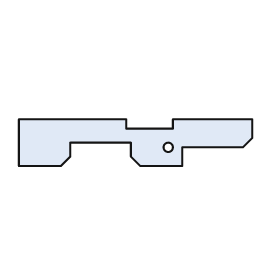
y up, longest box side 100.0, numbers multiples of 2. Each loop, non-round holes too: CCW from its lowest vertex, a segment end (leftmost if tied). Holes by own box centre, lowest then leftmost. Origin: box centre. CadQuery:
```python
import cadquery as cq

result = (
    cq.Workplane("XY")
    .moveTo(-50.0, -10.0)
    .lineTo(-32.0, -10.0)
    .lineTo(-28.0, -6.0)
    .lineTo(-28.0, 0.0)
    .lineTo(-2.0, 0.0)
    .lineTo(-2.0, -6.0)
    .lineTo(2.0, -10.0)
    .lineTo(20.0, -10.0)
    .lineTo(20.0, -2.0)
    .lineTo(46.0, -2.0)
    .lineTo(50.0, 2.0)
    .lineTo(50.0, 10.0)
    .lineTo(16.0, 10.0)
    .lineTo(16.0, 6.0)
    .lineTo(-4.0, 6.0)
    .lineTo(-4.0, 10.0)
    .lineTo(-50.0, 10.0)
    .close()
    .moveTo(14.0, -2.0)
    .circle(2.0)
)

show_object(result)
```